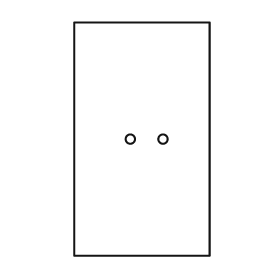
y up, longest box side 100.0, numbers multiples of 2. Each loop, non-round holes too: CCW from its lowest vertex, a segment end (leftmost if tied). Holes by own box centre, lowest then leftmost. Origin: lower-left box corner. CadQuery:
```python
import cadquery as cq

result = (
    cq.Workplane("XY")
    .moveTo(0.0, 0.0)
    .lineTo(58.0, 0.0)
    .lineTo(58.0, 100.0)
    .lineTo(0.0, 100.0)
    .close()
    .moveTo(24.0, 50.0)
    .circle(2.0)
    .moveTo(38.0, 50.0)
    .circle(2.0)
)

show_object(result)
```